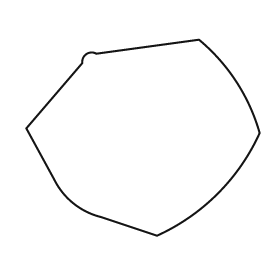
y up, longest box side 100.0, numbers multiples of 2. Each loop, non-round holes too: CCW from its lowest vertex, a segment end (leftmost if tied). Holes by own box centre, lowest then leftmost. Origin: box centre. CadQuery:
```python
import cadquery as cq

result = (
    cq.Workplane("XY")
    .moveTo(6.0, -42.0)
    .threePointArc((32.0, -24.0), (50.0, 2.0))
    .threePointArc((40.0, 24.0), (24.0, 42.0))
    .lineTo(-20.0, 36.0)
    .threePointArc((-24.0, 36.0), (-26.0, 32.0))
    .lineTo(-50.0, 4.0)
    .lineTo(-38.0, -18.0)
    .threePointArc((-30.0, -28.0), (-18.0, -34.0))
    .close()
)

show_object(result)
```